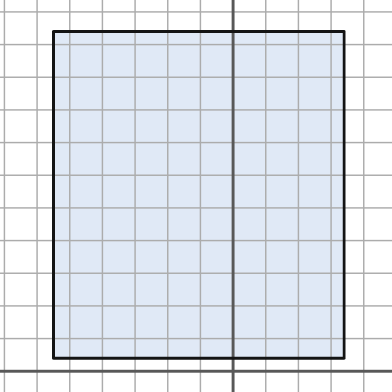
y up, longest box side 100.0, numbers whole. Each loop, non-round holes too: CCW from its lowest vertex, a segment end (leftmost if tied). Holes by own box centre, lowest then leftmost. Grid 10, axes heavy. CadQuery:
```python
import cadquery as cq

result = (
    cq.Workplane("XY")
    .moveTo(-55.0, 4.0)
    .lineTo(34.0, 4.0)
    .lineTo(34.0, 104.0)
    .lineTo(-55.0, 104.0)
    .close()
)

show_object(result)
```